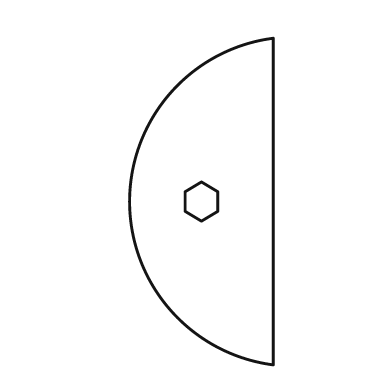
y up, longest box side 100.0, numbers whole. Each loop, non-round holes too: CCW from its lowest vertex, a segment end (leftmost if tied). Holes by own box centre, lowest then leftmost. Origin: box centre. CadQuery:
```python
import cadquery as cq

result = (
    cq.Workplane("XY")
    .moveTo(22.0, -50.0)
    .lineTo(22.0, 50.0)
    .threePointArc((-22.0, 0.0), (22.0, -50.0))
    .close()
    .moveTo(0.0, -6.0)
    .lineTo(5.0, -3.0)
    .lineTo(5.0, 3.0)
    .lineTo(0.0, 6.0)
    .lineTo(-5.0, 3.0)
    .lineTo(-5.0, -3.0)
    .close()
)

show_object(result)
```